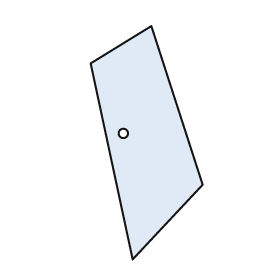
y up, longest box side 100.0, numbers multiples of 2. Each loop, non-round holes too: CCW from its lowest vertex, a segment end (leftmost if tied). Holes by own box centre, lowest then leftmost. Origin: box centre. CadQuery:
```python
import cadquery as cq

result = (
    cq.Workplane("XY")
    .moveTo(-6.0, -50.0)
    .lineTo(24.0, -18.0)
    .lineTo(2.0, 50.0)
    .lineTo(-24.0, 34.0)
    .close()
    .moveTo(-10.0, 4.0)
    .circle(2.0)
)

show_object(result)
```